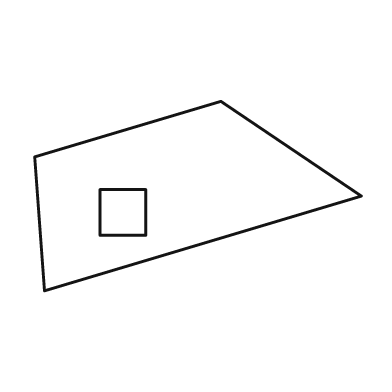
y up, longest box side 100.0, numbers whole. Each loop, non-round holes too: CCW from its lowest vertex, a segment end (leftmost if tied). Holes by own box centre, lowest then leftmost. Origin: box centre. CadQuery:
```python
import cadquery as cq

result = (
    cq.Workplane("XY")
    .moveTo(-47.0, -29.0)
    .lineTo(50.0, 0.0)
    .lineTo(7.0, 29.0)
    .lineTo(-50.0, 12.0)
    .close()
    .moveTo(-30.0, -12.0)
    .lineTo(-16.0, -12.0)
    .lineTo(-16.0, 2.0)
    .lineTo(-30.0, 2.0)
    .close()
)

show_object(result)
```